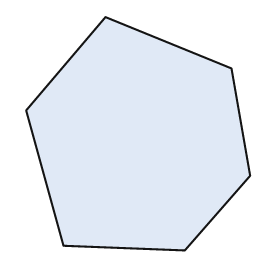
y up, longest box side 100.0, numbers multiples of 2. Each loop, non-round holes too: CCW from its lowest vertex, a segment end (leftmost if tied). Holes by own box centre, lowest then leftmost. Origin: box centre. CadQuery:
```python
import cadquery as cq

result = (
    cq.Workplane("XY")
    .moveTo(20.0, -50.0)
    .lineTo(48.0, -18.0)
    .lineTo(40.0, 28.0)
    .lineTo(-14.0, 50.0)
    .lineTo(-48.0, 10.0)
    .lineTo(-32.0, -48.0)
    .close()
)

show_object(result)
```